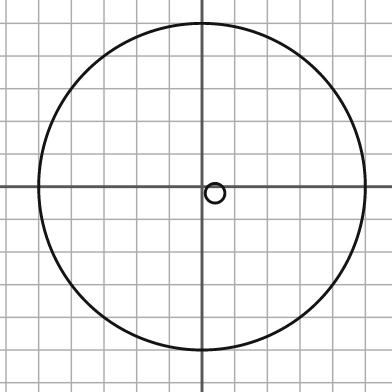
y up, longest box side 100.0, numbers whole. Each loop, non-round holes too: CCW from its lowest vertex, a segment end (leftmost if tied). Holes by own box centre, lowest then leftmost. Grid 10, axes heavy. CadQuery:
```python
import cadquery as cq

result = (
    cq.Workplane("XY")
    .moveTo(0.0, 0.0)
    .circle(50.0)
    .moveTo(4.0, -2.0)
    .circle(3.0)
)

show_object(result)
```